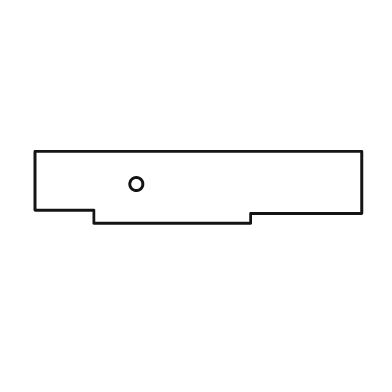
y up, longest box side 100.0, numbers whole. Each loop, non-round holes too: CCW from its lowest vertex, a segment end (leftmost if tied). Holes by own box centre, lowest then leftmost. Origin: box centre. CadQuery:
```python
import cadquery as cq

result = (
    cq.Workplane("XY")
    .moveTo(-32.0, -11.0)
    .lineTo(16.0, -11.0)
    .lineTo(16.0, -8.0)
    .lineTo(50.0, -8.0)
    .lineTo(50.0, 11.0)
    .lineTo(-50.0, 11.0)
    .lineTo(-50.0, -7.0)
    .lineTo(-32.0, -7.0)
    .close()
    .moveTo(-19.0, 1.0)
    .circle(2.0)
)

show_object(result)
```